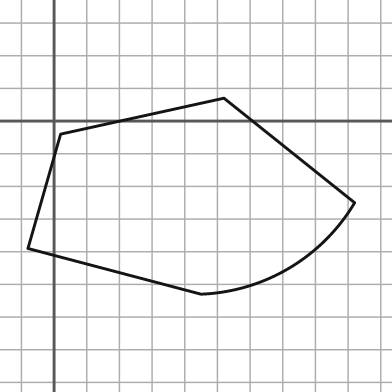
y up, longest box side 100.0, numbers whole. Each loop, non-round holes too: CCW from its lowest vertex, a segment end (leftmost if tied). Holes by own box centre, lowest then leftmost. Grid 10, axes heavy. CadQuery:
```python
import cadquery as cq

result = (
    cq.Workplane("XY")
    .moveTo(45.0, -53.0)
    .threePointArc((72.0, -45.0), (92.0, -25.0))
    .lineTo(52.0, 7.0)
    .lineTo(2.0, -4.0)
    .lineTo(-8.0, -39.0)
    .close()
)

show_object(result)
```